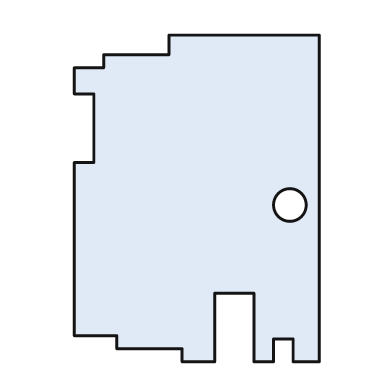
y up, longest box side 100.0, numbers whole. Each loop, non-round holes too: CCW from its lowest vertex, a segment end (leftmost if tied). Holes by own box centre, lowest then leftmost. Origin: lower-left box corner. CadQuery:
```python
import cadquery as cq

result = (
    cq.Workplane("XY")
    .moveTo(33.0, 0.0)
    .lineTo(43.0, 0.0)
    .lineTo(43.0, 21.0)
    .lineTo(55.0, 21.0)
    .lineTo(55.0, 0.0)
    .lineTo(61.0, 0.0)
    .lineTo(61.0, 7.0)
    .lineTo(67.0, 7.0)
    .lineTo(67.0, 0.0)
    .lineTo(75.0, 0.0)
    .lineTo(75.0, 100.0)
    .lineTo(29.0, 100.0)
    .lineTo(29.0, 94.0)
    .lineTo(9.0, 94.0)
    .lineTo(9.0, 90.0)
    .lineTo(0.0, 90.0)
    .lineTo(0.0, 82.0)
    .lineTo(6.0, 82.0)
    .lineTo(6.0, 61.0)
    .lineTo(0.0, 61.0)
    .lineTo(0.0, 8.0)
    .lineTo(13.0, 8.0)
    .lineTo(13.0, 4.0)
    .lineTo(33.0, 4.0)
    .close()
    .moveTo(66.0, 48.0)
    .circle(5.0)
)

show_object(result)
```